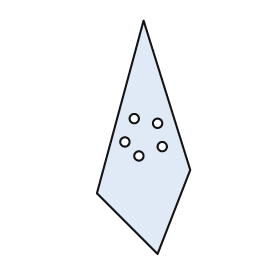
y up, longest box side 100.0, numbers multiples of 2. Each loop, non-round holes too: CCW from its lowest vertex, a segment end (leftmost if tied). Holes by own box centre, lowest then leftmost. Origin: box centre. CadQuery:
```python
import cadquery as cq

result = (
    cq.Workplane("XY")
    .moveTo(6.0, -50.0)
    .lineTo(20.0, -14.0)
    .lineTo(0.0, 50.0)
    .lineTo(-20.0, -24.0)
    .close()
    .moveTo(-2.0, -8.0)
    .circle(2.0)
    .moveTo(8.0, -4.0)
    .circle(2.0)
    .moveTo(-8.0, -2.0)
    .circle(2.0)
    .moveTo(6.0, 6.0)
    .circle(2.0)
    .moveTo(-4.0, 8.0)
    .circle(2.0)
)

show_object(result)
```